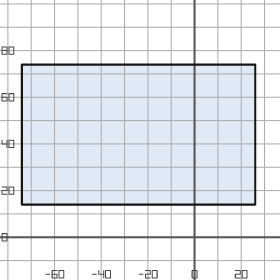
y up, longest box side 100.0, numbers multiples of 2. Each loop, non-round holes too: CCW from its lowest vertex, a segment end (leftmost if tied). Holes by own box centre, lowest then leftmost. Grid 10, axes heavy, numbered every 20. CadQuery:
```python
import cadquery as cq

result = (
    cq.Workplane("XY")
    .moveTo(-74.0, 14.0)
    .lineTo(26.0, 14.0)
    .lineTo(26.0, 74.0)
    .lineTo(-74.0, 74.0)
    .close()
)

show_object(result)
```